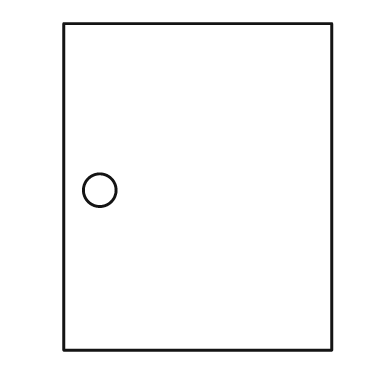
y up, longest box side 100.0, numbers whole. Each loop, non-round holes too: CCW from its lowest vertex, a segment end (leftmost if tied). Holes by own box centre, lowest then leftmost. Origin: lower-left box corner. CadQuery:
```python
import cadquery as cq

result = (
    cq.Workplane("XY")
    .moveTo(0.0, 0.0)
    .lineTo(82.0, 0.0)
    .lineTo(82.0, 100.0)
    .lineTo(0.0, 100.0)
    .close()
    .moveTo(11.0, 49.0)
    .circle(5.0)
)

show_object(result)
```